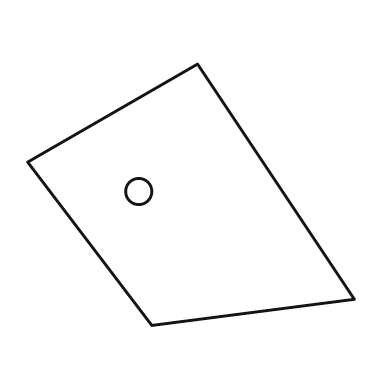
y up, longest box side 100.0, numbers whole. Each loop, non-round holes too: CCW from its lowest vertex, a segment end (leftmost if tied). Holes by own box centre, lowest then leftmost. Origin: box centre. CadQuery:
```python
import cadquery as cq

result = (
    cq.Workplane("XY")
    .moveTo(-12.0, -40.0)
    .lineTo(50.0, -32.0)
    .lineTo(2.0, 40.0)
    .lineTo(-50.0, 10.0)
    .close()
    .moveTo(-16.0, 1.0)
    .circle(4.0)
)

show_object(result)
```